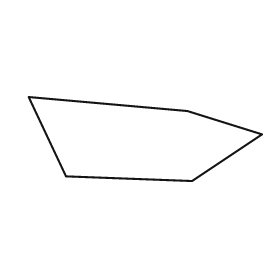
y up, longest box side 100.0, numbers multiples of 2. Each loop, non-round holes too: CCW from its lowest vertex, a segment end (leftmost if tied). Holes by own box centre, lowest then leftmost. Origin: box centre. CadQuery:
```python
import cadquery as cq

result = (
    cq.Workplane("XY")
    .moveTo(20.0, -18.0)
    .lineTo(50.0, 2.0)
    .lineTo(18.0, 12.0)
    .lineTo(-50.0, 18.0)
    .lineTo(-34.0, -16.0)
    .close()
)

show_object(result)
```